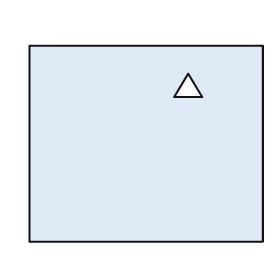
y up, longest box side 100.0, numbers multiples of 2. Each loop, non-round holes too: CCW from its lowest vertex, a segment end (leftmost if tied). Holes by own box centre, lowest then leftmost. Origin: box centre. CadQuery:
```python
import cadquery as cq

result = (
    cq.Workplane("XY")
    .moveTo(-50.0, -42.0)
    .lineTo(50.0, -42.0)
    .lineTo(50.0, 42.0)
    .lineTo(-50.0, 42.0)
    .close()
    .moveTo(12.0, 20.0)
    .lineTo(24.0, 20.0)
    .lineTo(18.0, 30.0)
    .close()
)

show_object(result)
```